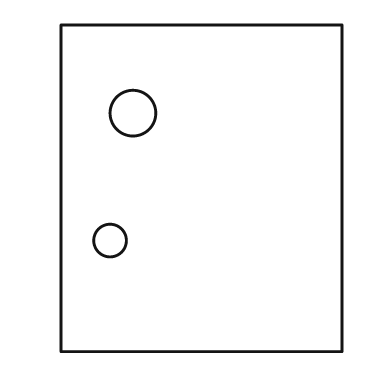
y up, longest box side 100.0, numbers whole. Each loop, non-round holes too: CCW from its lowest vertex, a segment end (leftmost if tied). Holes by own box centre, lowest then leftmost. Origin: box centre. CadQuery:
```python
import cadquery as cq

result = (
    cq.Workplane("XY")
    .moveTo(-43.0, -50.0)
    .lineTo(43.0, -50.0)
    .lineTo(43.0, 50.0)
    .lineTo(-43.0, 50.0)
    .close()
    .moveTo(-28.0, -16.0)
    .circle(5.0)
    .moveTo(-21.0, 23.0)
    .circle(7.0)
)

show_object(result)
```